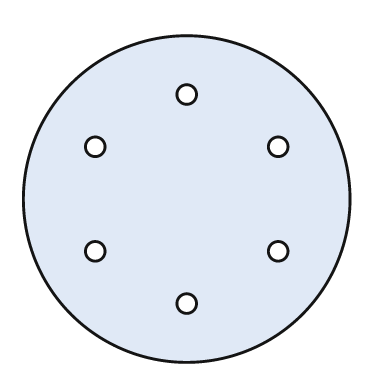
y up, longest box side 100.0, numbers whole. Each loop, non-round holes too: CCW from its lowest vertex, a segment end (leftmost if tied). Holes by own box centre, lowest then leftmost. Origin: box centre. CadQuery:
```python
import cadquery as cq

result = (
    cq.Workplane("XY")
    .moveTo(0.0, 0.0)
    .circle(50.0)
    .moveTo(0.0, -32.0)
    .circle(3.0)
    .moveTo(-28.0, -16.0)
    .circle(3.0)
    .moveTo(28.0, -16.0)
    .circle(3.0)
    .moveTo(-28.0, 16.0)
    .circle(3.0)
    .moveTo(28.0, 16.0)
    .circle(3.0)
    .moveTo(0.0, 32.0)
    .circle(3.0)
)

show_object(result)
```